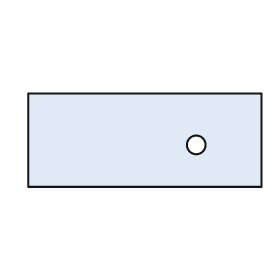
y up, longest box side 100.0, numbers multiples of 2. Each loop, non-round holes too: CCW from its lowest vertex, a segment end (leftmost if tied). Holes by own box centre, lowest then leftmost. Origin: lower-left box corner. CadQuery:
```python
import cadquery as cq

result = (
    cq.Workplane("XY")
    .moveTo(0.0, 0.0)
    .lineTo(100.0, 0.0)
    .lineTo(100.0, 40.0)
    .lineTo(0.0, 40.0)
    .close()
    .moveTo(72.0, 18.0)
    .circle(4.0)
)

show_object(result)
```